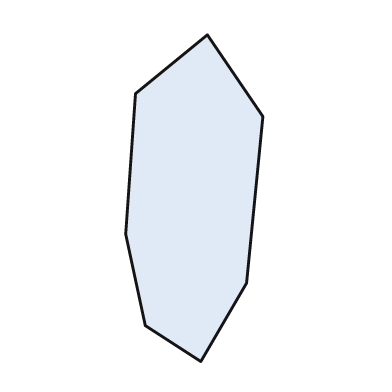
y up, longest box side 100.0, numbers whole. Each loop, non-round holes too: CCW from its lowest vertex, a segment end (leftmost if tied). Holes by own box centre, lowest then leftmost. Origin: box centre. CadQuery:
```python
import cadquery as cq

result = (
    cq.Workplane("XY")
    .moveTo(2.0, -50.0)
    .lineTo(16.0, -26.0)
    .lineTo(21.0, 25.0)
    .lineTo(4.0, 50.0)
    .lineTo(-18.0, 32.0)
    .lineTo(-21.0, -11.0)
    .lineTo(-15.0, -39.0)
    .close()
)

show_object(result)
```